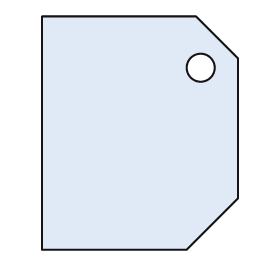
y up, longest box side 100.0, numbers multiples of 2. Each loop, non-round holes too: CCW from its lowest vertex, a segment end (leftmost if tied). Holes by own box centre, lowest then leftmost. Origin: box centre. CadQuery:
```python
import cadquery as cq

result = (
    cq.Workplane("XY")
    .moveTo(-42.0, -50.0)
    .lineTo(20.0, -50.0)
    .lineTo(42.0, -28.0)
    .lineTo(42.0, 32.0)
    .lineTo(24.0, 50.0)
    .lineTo(-42.0, 50.0)
    .close()
    .moveTo(26.0, 28.0)
    .circle(6.0)
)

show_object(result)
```